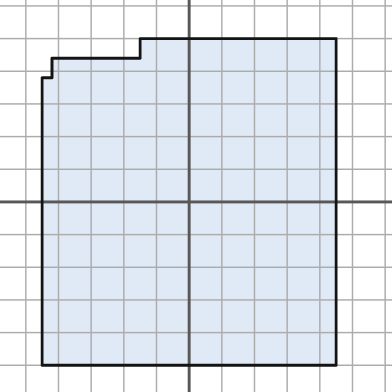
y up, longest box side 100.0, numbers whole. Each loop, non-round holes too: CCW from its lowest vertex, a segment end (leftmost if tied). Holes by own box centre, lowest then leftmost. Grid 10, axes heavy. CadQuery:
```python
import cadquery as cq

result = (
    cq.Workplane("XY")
    .moveTo(-45.0, -50.0)
    .lineTo(45.0, -50.0)
    .lineTo(45.0, 50.0)
    .lineTo(-15.0, 50.0)
    .lineTo(-15.0, 44.0)
    .lineTo(-42.0, 44.0)
    .lineTo(-42.0, 38.0)
    .lineTo(-45.0, 38.0)
    .close()
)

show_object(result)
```